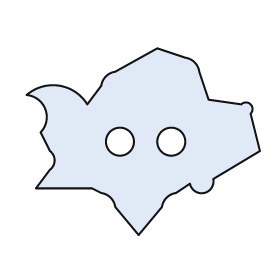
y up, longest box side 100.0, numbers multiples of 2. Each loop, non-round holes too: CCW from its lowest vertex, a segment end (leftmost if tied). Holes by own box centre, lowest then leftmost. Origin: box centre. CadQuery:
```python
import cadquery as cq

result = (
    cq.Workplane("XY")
    .moveTo(-2.0, -40.0)
    .lineTo(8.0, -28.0)
    .threePointArc((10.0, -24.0), (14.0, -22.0))
    .lineTo(20.0, -18.0)
    .threePointArc((26.0, -22.0), (30.0, -16.0))
    .lineTo(50.0, -4.0)
    .lineTo(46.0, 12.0)
    .threePointArc((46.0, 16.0), (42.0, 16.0))
    .lineTo(28.0, 18.0)
    .lineTo(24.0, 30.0)
    .threePointArc((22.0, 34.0), (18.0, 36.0))
    .lineTo(6.0, 40.0)
    .lineTo(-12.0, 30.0)
    .threePointArc((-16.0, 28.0), (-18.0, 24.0))
    .lineTo(-24.0, 16.0)
    .threePointArc((-36.0, 24.0), (-50.0, 20.0))
    .threePointArc((-42.0, 14.0), (-44.0, 4.0))
    .lineTo(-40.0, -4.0)
    .threePointArc((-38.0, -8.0), (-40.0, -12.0))
    .lineTo(-46.0, -20.0)
    .lineTo(-22.0, -20.0)
    .lineTo(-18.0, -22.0)
    .threePointArc((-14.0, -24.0), (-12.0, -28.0))
    .close()
    .moveTo(-10.0, 0.0)
    .circle(6.0)
    .moveTo(12.0, 0.0)
    .circle(6.0)
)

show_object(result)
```